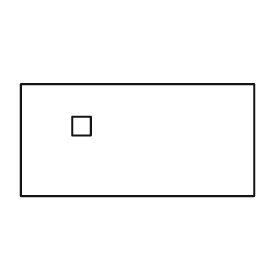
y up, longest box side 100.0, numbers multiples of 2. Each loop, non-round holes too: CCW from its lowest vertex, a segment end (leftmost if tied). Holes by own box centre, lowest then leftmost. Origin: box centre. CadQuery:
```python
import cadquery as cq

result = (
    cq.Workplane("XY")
    .moveTo(-50.0, -24.0)
    .lineTo(50.0, -24.0)
    .lineTo(50.0, 24.0)
    .lineTo(-50.0, 24.0)
    .close()
    .moveTo(-28.0, 2.0)
    .lineTo(-20.0, 2.0)
    .lineTo(-20.0, 10.0)
    .lineTo(-28.0, 10.0)
    .close()
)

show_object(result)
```